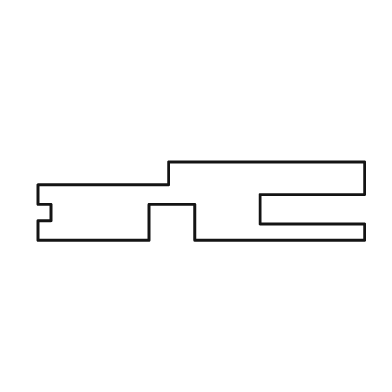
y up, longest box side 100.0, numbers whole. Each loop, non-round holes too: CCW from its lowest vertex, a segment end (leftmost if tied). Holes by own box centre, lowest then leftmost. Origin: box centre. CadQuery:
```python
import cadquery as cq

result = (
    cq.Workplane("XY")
    .moveTo(-50.0, -12.0)
    .lineTo(-16.0, -12.0)
    .lineTo(-16.0, -1.0)
    .lineTo(-2.0, -1.0)
    .lineTo(-2.0, -12.0)
    .lineTo(50.0, -12.0)
    .lineTo(50.0, -7.0)
    .lineTo(18.0, -7.0)
    .lineTo(18.0, 2.0)
    .lineTo(50.0, 2.0)
    .lineTo(50.0, 12.0)
    .lineTo(-10.0, 12.0)
    .lineTo(-10.0, 5.0)
    .lineTo(-50.0, 5.0)
    .lineTo(-50.0, -1.0)
    .lineTo(-46.0, -1.0)
    .lineTo(-46.0, -6.0)
    .lineTo(-50.0, -6.0)
    .close()
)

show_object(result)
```